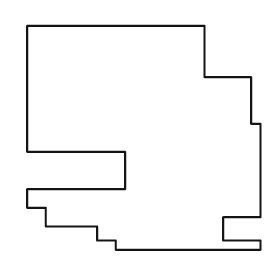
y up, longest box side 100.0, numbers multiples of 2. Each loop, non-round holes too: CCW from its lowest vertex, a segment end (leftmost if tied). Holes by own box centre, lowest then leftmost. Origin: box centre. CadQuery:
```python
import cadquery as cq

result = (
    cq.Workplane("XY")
    .moveTo(-12.0, -48.0)
    .lineTo(50.0, -48.0)
    .lineTo(50.0, -44.0)
    .lineTo(34.0, -44.0)
    .lineTo(34.0, -34.0)
    .lineTo(50.0, -34.0)
    .lineTo(50.0, 6.0)
    .lineTo(46.0, 6.0)
    .lineTo(46.0, 26.0)
    .lineTo(26.0, 26.0)
    .lineTo(26.0, 48.0)
    .lineTo(-50.0, 48.0)
    .lineTo(-50.0, -6.0)
    .lineTo(-8.0, -6.0)
    .lineTo(-8.0, -22.0)
    .lineTo(-50.0, -22.0)
    .lineTo(-50.0, -30.0)
    .lineTo(-42.0, -30.0)
    .lineTo(-42.0, -38.0)
    .lineTo(-20.0, -38.0)
    .lineTo(-20.0, -44.0)
    .lineTo(-12.0, -44.0)
    .close()
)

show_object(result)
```